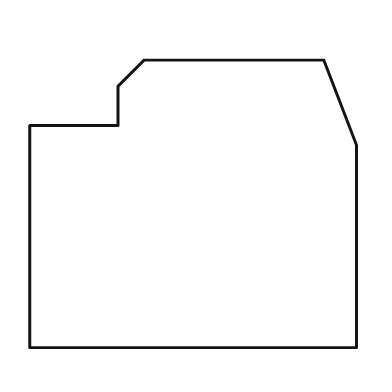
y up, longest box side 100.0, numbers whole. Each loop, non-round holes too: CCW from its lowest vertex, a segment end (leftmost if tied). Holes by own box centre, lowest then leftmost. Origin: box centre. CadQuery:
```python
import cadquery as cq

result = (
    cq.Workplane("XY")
    .moveTo(-50.0, -44.0)
    .lineTo(50.0, -44.0)
    .lineTo(50.0, 18.0)
    .lineTo(40.0, 44.0)
    .lineTo(-15.0, 44.0)
    .lineTo(-23.0, 36.0)
    .lineTo(-23.0, 24.0)
    .lineTo(-50.0, 24.0)
    .close()
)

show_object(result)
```